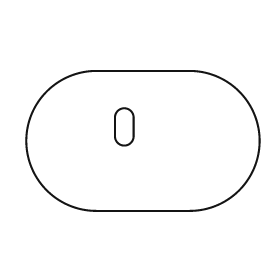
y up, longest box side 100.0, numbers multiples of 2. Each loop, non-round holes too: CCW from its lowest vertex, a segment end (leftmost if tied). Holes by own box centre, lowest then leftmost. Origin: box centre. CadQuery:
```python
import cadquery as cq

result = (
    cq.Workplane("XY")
    .moveTo(-20.0, -30.0)
    .lineTo(20.0, -30.0)
    .threePointArc((50.0, 0.0), (20.0, 30.0))
    .lineTo(-20.0, 30.0)
    .threePointArc((-50.0, 0.0), (-20.0, -30.0))
    .close()
    .moveTo(-12.0, 2.0)
    .threePointArc((-8.0, -2.0), (-4.0, 2.0))
    .lineTo(-4.0, 10.0)
    .threePointArc((-8.0, 14.0), (-12.0, 10.0))
    .close()
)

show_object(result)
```